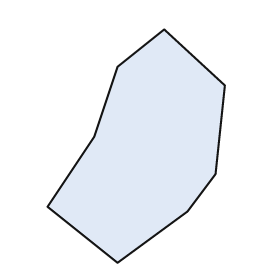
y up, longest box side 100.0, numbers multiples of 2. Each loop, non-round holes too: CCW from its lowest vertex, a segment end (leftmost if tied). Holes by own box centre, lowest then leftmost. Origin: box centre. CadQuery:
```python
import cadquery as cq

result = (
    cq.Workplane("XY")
    .moveTo(-8.0, -50.0)
    .lineTo(22.0, -28.0)
    .lineTo(34.0, -12.0)
    .lineTo(38.0, 26.0)
    .lineTo(12.0, 50.0)
    .lineTo(-8.0, 34.0)
    .lineTo(-18.0, 4.0)
    .lineTo(-38.0, -26.0)
    .close()
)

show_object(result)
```